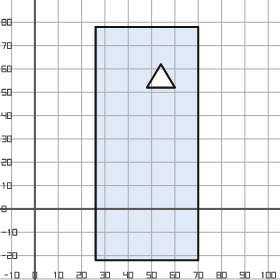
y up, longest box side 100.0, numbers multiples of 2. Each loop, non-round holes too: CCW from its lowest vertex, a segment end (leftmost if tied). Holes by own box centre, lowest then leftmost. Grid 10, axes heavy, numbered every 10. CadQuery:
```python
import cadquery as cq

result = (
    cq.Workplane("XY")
    .moveTo(26.0, -22.0)
    .lineTo(70.0, -22.0)
    .lineTo(70.0, 78.0)
    .lineTo(26.0, 78.0)
    .close()
    .moveTo(48.0, 52.0)
    .lineTo(60.0, 52.0)
    .lineTo(54.0, 62.0)
    .close()
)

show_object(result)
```